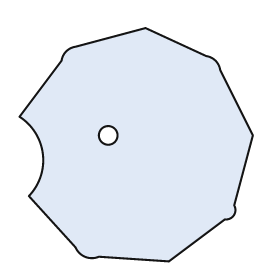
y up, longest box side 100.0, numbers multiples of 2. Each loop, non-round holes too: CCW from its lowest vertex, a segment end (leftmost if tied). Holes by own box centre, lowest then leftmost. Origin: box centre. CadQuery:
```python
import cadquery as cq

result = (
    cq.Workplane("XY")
    .moveTo(14.0, -50.0)
    .lineTo(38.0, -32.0)
    .threePointArc((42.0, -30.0), (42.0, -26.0))
    .lineTo(50.0, 4.0)
    .lineTo(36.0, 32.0)
    .threePointArc((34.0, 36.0), (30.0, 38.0))
    .lineTo(4.0, 50.0)
    .lineTo(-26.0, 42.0)
    .threePointArc((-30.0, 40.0), (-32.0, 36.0))
    .lineTo(-50.0, 12.0)
    .threePointArc((-40.0, -4.0), (-46.0, -22.0))
    .lineTo(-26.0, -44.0)
    .threePointArc((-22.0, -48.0), (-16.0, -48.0))
    .close()
    .moveTo(-12.0, 4.0)
    .circle(4.0)
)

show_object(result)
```